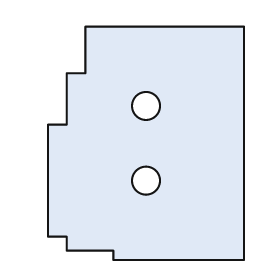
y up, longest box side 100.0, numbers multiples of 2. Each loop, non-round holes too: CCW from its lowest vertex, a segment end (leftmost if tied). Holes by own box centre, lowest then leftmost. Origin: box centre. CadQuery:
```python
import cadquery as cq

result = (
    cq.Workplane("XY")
    .moveTo(-14.0, -50.0)
    .lineTo(42.0, -50.0)
    .lineTo(42.0, 50.0)
    .lineTo(-26.0, 50.0)
    .lineTo(-26.0, 30.0)
    .lineTo(-34.0, 30.0)
    .lineTo(-34.0, 8.0)
    .lineTo(-42.0, 8.0)
    .lineTo(-42.0, -40.0)
    .lineTo(-34.0, -40.0)
    .lineTo(-34.0, -46.0)
    .lineTo(-14.0, -46.0)
    .close()
    .moveTo(0.0, -16.0)
    .circle(6.0)
    .moveTo(0.0, 16.0)
    .circle(6.0)
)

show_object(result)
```